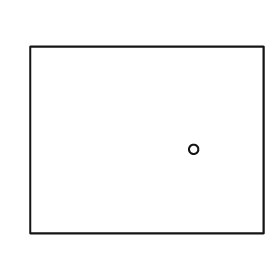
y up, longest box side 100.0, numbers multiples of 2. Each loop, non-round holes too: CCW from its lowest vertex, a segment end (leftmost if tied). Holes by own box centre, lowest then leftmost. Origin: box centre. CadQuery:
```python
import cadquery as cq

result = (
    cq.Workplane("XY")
    .moveTo(-50.0, -40.0)
    .lineTo(50.0, -40.0)
    .lineTo(50.0, 40.0)
    .lineTo(-50.0, 40.0)
    .close()
    .moveTo(20.0, -4.0)
    .circle(2.0)
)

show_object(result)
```